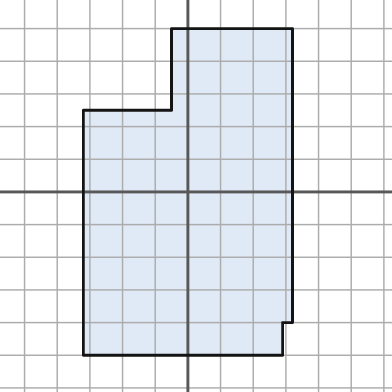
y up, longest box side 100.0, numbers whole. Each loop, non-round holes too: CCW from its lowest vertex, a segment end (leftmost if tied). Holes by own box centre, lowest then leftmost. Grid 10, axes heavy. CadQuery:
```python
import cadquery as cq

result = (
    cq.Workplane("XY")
    .moveTo(-32.0, -50.0)
    .lineTo(29.0, -50.0)
    .lineTo(29.0, -40.0)
    .lineTo(32.0, -40.0)
    .lineTo(32.0, 50.0)
    .lineTo(-5.0, 50.0)
    .lineTo(-5.0, 25.0)
    .lineTo(-32.0, 25.0)
    .close()
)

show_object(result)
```